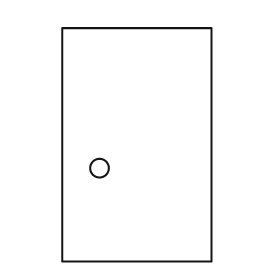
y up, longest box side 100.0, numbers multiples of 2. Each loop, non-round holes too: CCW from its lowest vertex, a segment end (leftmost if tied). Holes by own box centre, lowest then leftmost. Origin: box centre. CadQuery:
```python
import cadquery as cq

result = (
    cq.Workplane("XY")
    .moveTo(-32.0, -50.0)
    .lineTo(32.0, -50.0)
    .lineTo(32.0, 50.0)
    .lineTo(-32.0, 50.0)
    .close()
    .moveTo(-16.0, -10.0)
    .circle(4.0)
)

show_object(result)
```